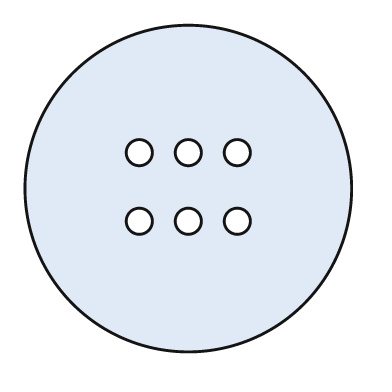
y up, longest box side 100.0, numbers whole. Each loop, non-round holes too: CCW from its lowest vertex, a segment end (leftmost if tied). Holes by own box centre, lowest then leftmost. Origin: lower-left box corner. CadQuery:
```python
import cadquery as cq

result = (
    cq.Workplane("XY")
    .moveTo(50.0, 50.0)
    .circle(50.0)
    .moveTo(35.0, 40.0)
    .circle(4.0)
    .moveTo(50.0, 40.0)
    .circle(4.0)
    .moveTo(65.0, 40.0)
    .circle(4.0)
    .moveTo(35.0, 61.0)
    .circle(4.0)
    .moveTo(50.0, 61.0)
    .circle(4.0)
    .moveTo(65.0, 61.0)
    .circle(4.0)
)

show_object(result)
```